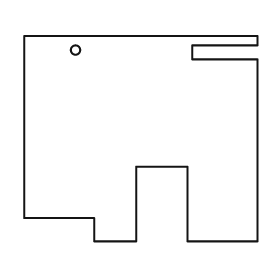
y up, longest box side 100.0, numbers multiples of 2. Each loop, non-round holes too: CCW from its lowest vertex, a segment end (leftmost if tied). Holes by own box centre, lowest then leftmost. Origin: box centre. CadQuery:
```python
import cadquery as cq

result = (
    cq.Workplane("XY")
    .moveTo(-20.0, -44.0)
    .lineTo(-2.0, -44.0)
    .lineTo(-2.0, -12.0)
    .lineTo(20.0, -12.0)
    .lineTo(20.0, -44.0)
    .lineTo(50.0, -44.0)
    .lineTo(50.0, 34.0)
    .lineTo(22.0, 34.0)
    .lineTo(22.0, 40.0)
    .lineTo(50.0, 40.0)
    .lineTo(50.0, 44.0)
    .lineTo(-50.0, 44.0)
    .lineTo(-50.0, -34.0)
    .lineTo(-20.0, -34.0)
    .close()
    .moveTo(-28.0, 38.0)
    .circle(2.0)
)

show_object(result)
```